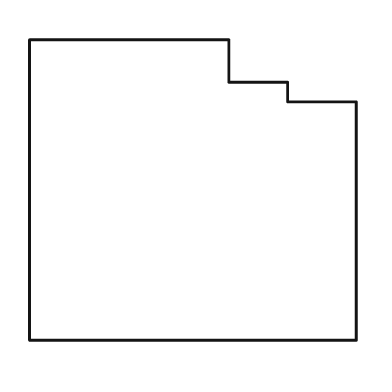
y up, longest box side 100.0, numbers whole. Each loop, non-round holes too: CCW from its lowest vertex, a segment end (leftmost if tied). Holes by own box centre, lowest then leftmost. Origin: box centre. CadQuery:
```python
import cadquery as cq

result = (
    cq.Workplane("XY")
    .moveTo(-50.0, -46.0)
    .lineTo(50.0, -46.0)
    .lineTo(50.0, 27.0)
    .lineTo(29.0, 27.0)
    .lineTo(29.0, 33.0)
    .lineTo(11.0, 33.0)
    .lineTo(11.0, 46.0)
    .lineTo(-50.0, 46.0)
    .close()
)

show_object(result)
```